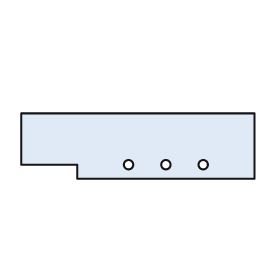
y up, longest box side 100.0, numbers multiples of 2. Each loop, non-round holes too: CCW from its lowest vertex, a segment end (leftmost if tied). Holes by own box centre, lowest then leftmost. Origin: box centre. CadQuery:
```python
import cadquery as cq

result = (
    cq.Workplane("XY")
    .moveTo(-26.0, -14.0)
    .lineTo(50.0, -14.0)
    .lineTo(50.0, 14.0)
    .lineTo(-50.0, 14.0)
    .lineTo(-50.0, -8.0)
    .lineTo(-26.0, -8.0)
    .close()
    .moveTo(-4.0, -8.0)
    .circle(2.0)
    .moveTo(12.0, -8.0)
    .circle(2.0)
    .moveTo(28.0, -8.0)
    .circle(2.0)
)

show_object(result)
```